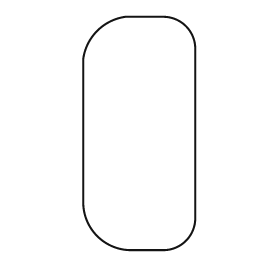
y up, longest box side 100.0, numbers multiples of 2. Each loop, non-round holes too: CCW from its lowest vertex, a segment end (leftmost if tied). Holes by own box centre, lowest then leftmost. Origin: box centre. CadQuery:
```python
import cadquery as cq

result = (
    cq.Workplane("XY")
    .moveTo(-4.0, -50.0)
    .lineTo(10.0, -50.0)
    .threePointArc((20.0, -46.0), (24.0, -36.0))
    .lineTo(24.0, 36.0)
    .threePointArc((20.0, 46.0), (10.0, 50.0))
    .lineTo(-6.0, 50.0)
    .threePointArc((-18.0, 44.0), (-24.0, 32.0))
    .lineTo(-24.0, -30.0)
    .threePointArc((-18.0, -44.0), (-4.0, -50.0))
    .close()
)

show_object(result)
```